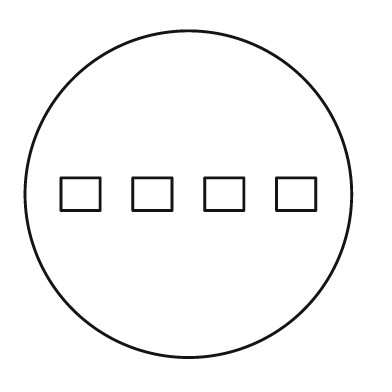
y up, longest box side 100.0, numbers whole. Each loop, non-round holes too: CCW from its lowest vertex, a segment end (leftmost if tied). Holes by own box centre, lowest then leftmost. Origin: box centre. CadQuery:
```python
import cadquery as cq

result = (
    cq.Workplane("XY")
    .moveTo(0.0, 0.0)
    .circle(50.0)
    .moveTo(-39.0, -5.0)
    .lineTo(-27.0, -5.0)
    .lineTo(-27.0, 5.0)
    .lineTo(-39.0, 5.0)
    .close()
    .moveTo(-17.0, -5.0)
    .lineTo(-5.0, -5.0)
    .lineTo(-5.0, 5.0)
    .lineTo(-17.0, 5.0)
    .close()
    .moveTo(5.0, -5.0)
    .lineTo(17.0, -5.0)
    .lineTo(17.0, 5.0)
    .lineTo(5.0, 5.0)
    .close()
    .moveTo(27.0, -5.0)
    .lineTo(39.0, -5.0)
    .lineTo(39.0, 5.0)
    .lineTo(27.0, 5.0)
    .close()
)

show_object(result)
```